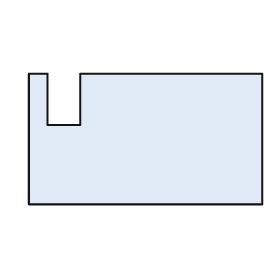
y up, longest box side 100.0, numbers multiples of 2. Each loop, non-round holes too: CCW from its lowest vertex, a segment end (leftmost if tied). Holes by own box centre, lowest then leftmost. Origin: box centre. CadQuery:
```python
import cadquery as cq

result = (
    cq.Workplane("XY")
    .moveTo(-50.0, -28.0)
    .lineTo(50.0, -28.0)
    .lineTo(50.0, 28.0)
    .lineTo(-28.0, 28.0)
    .lineTo(-28.0, 6.0)
    .lineTo(-42.0, 6.0)
    .lineTo(-42.0, 28.0)
    .lineTo(-50.0, 28.0)
    .close()
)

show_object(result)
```